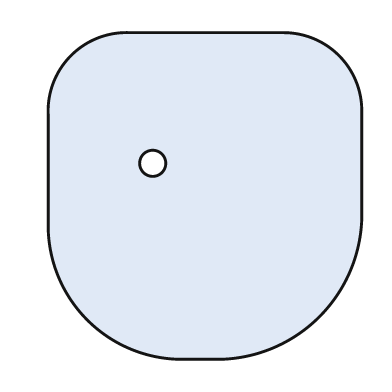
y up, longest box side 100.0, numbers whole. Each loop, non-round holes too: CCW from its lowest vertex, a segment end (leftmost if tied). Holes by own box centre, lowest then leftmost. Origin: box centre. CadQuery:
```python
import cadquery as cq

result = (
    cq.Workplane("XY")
    .moveTo(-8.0, -50.0)
    .lineTo(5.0, -50.0)
    .threePointArc((35.0, -37.0), (48.0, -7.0))
    .lineTo(48.0, 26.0)
    .threePointArc((41.0, 43.0), (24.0, 50.0))
    .lineTo(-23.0, 50.0)
    .threePointArc((-41.0, 43.0), (-48.0, 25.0))
    .lineTo(-48.0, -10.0)
    .threePointArc((-36.0, -38.0), (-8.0, -50.0))
    .close()
    .moveTo(-16.0, 10.0)
    .circle(4.0)
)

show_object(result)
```